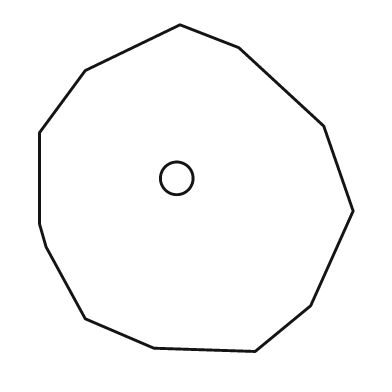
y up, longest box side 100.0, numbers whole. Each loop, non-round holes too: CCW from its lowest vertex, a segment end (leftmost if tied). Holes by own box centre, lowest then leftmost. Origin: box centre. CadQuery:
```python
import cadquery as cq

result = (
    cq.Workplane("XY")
    .moveTo(18.0, -50.0)
    .lineTo(35.0, -36.0)
    .lineTo(48.0, -7.0)
    .lineTo(39.0, 19.0)
    .lineTo(13.0, 43.0)
    .lineTo(-5.0, 50.0)
    .lineTo(-34.0, 36.0)
    .lineTo(-48.0, 17.0)
    .lineTo(-48.0, -11.0)
    .lineTo(-46.0, -18.0)
    .lineTo(-34.0, -40.0)
    .lineTo(-13.0, -49.0)
    .close()
    .moveTo(-6.0, 3.0)
    .circle(5.0)
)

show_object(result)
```